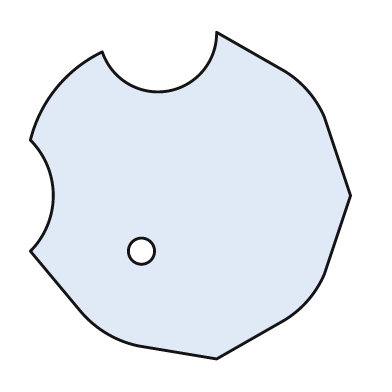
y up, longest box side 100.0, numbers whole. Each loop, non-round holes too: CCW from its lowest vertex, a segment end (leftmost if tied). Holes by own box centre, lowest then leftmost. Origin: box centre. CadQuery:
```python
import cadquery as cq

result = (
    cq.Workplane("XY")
    .moveTo(8.0, -50.0)
    .lineTo(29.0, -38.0)
    .threePointArc((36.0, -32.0), (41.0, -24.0))
    .lineTo(49.0, 0.0)
    .lineTo(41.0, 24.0)
    .threePointArc((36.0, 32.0), (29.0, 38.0))
    .lineTo(8.0, 50.0)
    .threePointArc((-7.0, 32.0), (-27.0, 44.0))
    .threePointArc((-41.0, 33.0), (-49.0, 17.0))
    .threePointArc((-42.0, 0.0), (-49.0, -17.0))
    .lineTo(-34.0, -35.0)
    .threePointArc((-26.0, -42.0), (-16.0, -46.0))
    .close()
    .moveTo(-15.0, -17.0)
    .circle(4.0)
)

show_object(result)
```